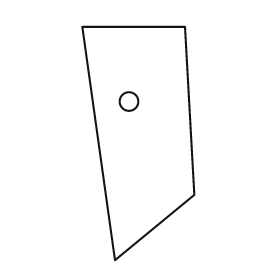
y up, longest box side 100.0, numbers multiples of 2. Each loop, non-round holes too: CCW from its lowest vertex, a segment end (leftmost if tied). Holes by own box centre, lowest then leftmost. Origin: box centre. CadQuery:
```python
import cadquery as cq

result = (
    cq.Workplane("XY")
    .moveTo(-10.0, -50.0)
    .lineTo(24.0, -22.0)
    .lineTo(20.0, 50.0)
    .lineTo(-24.0, 50.0)
    .close()
    .moveTo(-4.0, 18.0)
    .circle(4.0)
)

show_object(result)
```